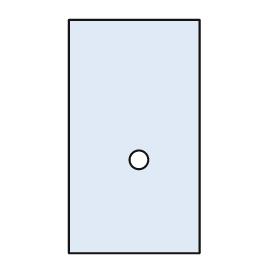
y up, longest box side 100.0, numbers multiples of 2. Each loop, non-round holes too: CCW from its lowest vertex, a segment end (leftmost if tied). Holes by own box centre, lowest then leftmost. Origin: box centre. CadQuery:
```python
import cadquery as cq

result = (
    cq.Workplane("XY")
    .moveTo(-28.0, -50.0)
    .lineTo(28.0, -50.0)
    .lineTo(28.0, 50.0)
    .lineTo(-28.0, 50.0)
    .close()
    .moveTo(2.0, -10.0)
    .circle(4.0)
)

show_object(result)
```